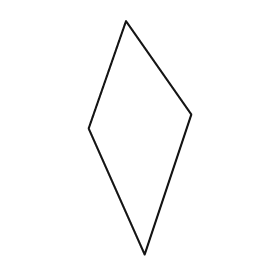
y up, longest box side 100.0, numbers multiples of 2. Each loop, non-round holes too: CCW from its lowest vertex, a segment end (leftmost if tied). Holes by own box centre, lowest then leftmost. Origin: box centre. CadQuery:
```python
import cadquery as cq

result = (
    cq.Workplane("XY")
    .moveTo(2.0, -50.0)
    .lineTo(22.0, 10.0)
    .lineTo(-6.0, 50.0)
    .lineTo(-22.0, 4.0)
    .close()
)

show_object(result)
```